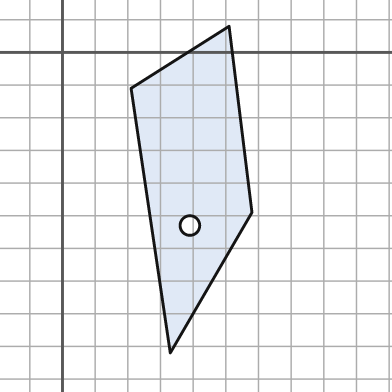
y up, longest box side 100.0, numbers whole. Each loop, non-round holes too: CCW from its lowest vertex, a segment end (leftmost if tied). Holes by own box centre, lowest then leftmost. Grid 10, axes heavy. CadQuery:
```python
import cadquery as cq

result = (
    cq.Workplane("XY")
    .moveTo(33.0, -92.0)
    .lineTo(58.0, -49.0)
    .lineTo(51.0, 8.0)
    .lineTo(21.0, -11.0)
    .close()
    .moveTo(39.0, -53.0)
    .circle(3.0)
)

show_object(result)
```